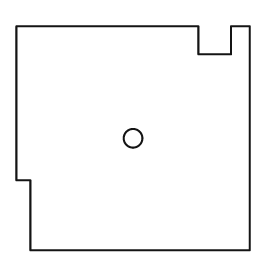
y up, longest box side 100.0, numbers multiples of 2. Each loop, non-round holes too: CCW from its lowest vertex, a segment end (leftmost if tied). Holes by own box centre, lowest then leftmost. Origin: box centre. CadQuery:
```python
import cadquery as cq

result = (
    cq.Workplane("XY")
    .moveTo(-44.0, -48.0)
    .lineTo(50.0, -48.0)
    .lineTo(50.0, 48.0)
    .lineTo(42.0, 48.0)
    .lineTo(42.0, 36.0)
    .lineTo(28.0, 36.0)
    .lineTo(28.0, 48.0)
    .lineTo(-50.0, 48.0)
    .lineTo(-50.0, -18.0)
    .lineTo(-44.0, -18.0)
    .close()
    .moveTo(0.0, 0.0)
    .circle(4.0)
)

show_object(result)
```